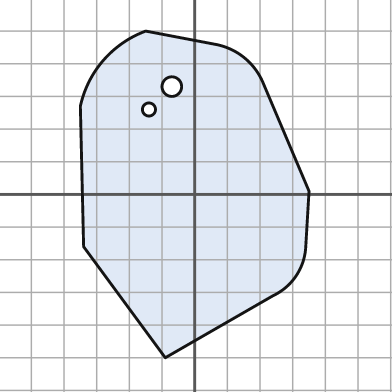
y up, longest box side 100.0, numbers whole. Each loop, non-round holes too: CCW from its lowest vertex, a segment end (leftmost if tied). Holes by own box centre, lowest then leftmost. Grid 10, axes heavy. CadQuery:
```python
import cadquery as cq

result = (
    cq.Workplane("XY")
    .moveTo(-9.0, -50.0)
    .lineTo(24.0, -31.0)
    .threePointArc((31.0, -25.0), (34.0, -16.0))
    .lineTo(35.0, 1.0)
    .lineTo(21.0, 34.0)
    .threePointArc((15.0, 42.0), (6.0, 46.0))
    .lineTo(-15.0, 50.0)
    .threePointArc((-28.0, 41.0), (-35.0, 27.0))
    .lineTo(-34.0, -16.0)
    .close()
    .moveTo(-14.0, 26.0)
    .circle(2.0)
    .moveTo(-7.0, 33.0)
    .circle(3.0)
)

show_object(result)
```